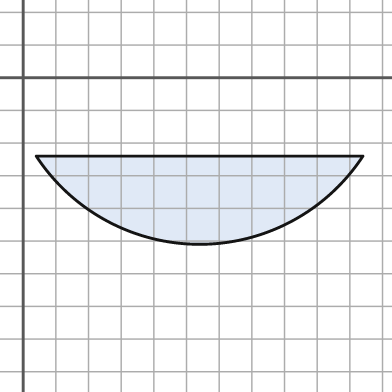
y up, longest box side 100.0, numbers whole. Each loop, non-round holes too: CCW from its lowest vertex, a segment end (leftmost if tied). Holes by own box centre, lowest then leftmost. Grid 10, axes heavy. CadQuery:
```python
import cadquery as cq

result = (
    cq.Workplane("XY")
    .moveTo(4.0, -24.0)
    .threePointArc((54.0, -51.0), (104.0, -24.0))
    .close()
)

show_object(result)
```